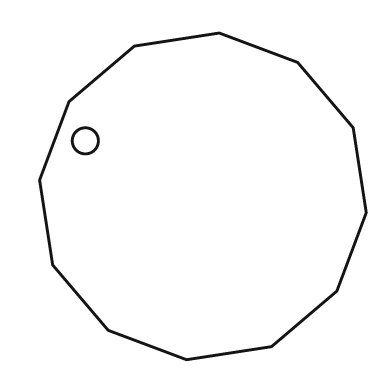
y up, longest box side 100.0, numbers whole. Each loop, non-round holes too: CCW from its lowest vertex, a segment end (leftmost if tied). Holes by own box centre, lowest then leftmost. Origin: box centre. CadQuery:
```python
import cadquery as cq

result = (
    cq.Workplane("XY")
    .moveTo(-5.0, -50.0)
    .lineTo(21.0, -46.0)
    .lineTo(41.0, -29.0)
    .lineTo(50.0, -5.0)
    .lineTo(46.0, 21.0)
    .lineTo(29.0, 41.0)
    .lineTo(5.0, 50.0)
    .lineTo(-21.0, 46.0)
    .lineTo(-41.0, 29.0)
    .lineTo(-50.0, 5.0)
    .lineTo(-46.0, -21.0)
    .lineTo(-29.0, -41.0)
    .close()
    .moveTo(-36.0, 17.0)
    .circle(4.0)
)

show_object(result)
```